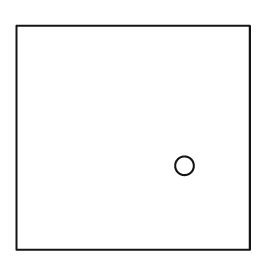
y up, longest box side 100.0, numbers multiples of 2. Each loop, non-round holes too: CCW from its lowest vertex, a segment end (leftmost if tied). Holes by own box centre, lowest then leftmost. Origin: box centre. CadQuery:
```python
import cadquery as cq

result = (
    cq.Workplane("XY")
    .moveTo(-50.0, -48.0)
    .lineTo(50.0, -48.0)
    .lineTo(50.0, 48.0)
    .lineTo(-50.0, 48.0)
    .close()
    .moveTo(22.0, -12.0)
    .circle(4.0)
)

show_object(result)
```